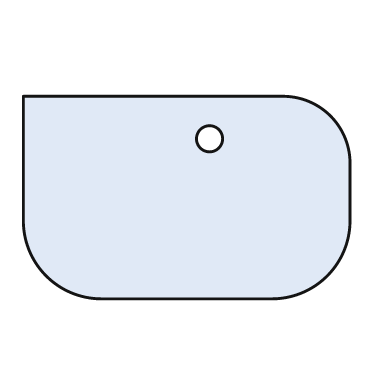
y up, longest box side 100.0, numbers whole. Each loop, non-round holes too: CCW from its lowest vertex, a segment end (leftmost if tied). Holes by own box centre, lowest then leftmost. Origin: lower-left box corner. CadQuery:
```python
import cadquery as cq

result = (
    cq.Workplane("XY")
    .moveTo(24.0, 0.0)
    .lineTo(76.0, 0.0)
    .threePointArc((93.0, 7.0), (100.0, 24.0))
    .lineTo(100.0, 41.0)
    .threePointArc((94.0, 56.0), (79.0, 62.0))
    .lineTo(0.0, 62.0)
    .lineTo(0.0, 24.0)
    .threePointArc((7.0, 7.0), (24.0, 0.0))
    .close()
    .moveTo(57.0, 49.0)
    .circle(4.0)
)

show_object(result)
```